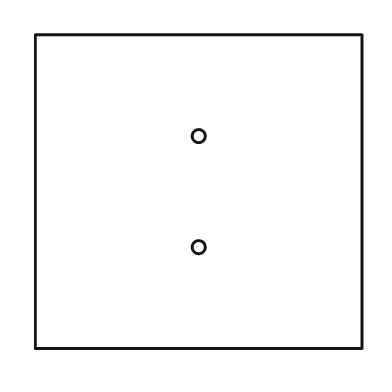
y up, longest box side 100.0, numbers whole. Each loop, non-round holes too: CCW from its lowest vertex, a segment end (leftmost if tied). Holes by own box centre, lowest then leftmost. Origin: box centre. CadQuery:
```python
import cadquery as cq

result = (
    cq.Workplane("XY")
    .moveTo(-50.0, -48.0)
    .lineTo(50.0, -48.0)
    .lineTo(50.0, 48.0)
    .lineTo(-50.0, 48.0)
    .close()
    .moveTo(0.0, -17.0)
    .circle(2.0)
    .moveTo(0.0, 17.0)
    .circle(2.0)
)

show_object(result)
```